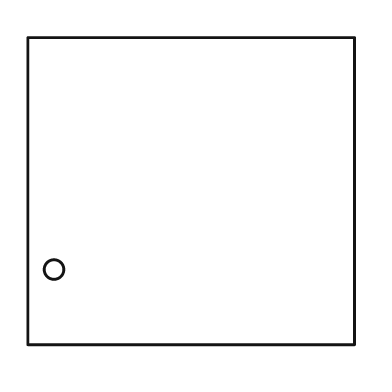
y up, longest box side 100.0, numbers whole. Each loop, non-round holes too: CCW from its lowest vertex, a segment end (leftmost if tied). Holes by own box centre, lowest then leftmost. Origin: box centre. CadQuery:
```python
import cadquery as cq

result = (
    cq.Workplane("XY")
    .moveTo(-50.0, -47.0)
    .lineTo(50.0, -47.0)
    .lineTo(50.0, 47.0)
    .lineTo(-50.0, 47.0)
    .close()
    .moveTo(-42.0, -24.0)
    .circle(3.0)
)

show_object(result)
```